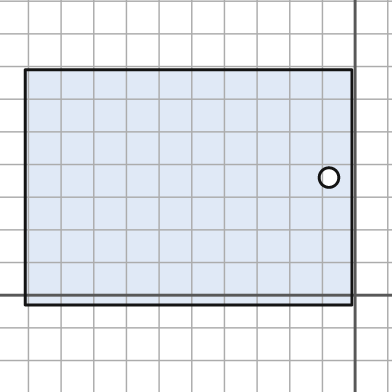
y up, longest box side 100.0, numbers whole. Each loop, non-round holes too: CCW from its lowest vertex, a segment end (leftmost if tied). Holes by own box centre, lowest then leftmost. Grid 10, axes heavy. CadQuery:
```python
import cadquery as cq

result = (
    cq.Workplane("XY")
    .moveTo(-101.0, -3.0)
    .lineTo(-1.0, -3.0)
    .lineTo(-1.0, 69.0)
    .lineTo(-101.0, 69.0)
    .close()
    .moveTo(-8.0, 36.0)
    .circle(3.0)
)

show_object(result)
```